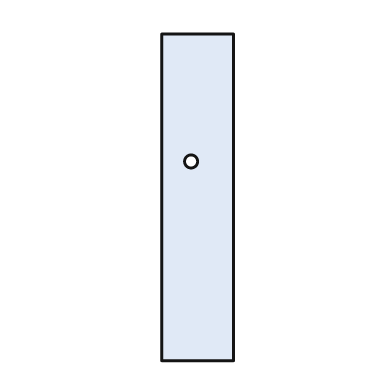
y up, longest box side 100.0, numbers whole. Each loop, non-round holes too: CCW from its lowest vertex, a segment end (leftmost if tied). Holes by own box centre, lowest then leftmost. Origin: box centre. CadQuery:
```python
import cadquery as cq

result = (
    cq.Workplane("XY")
    .moveTo(-11.0, -50.0)
    .lineTo(11.0, -50.0)
    .lineTo(11.0, 50.0)
    .lineTo(-11.0, 50.0)
    .close()
    .moveTo(-2.0, 11.0)
    .circle(2.0)
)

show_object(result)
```